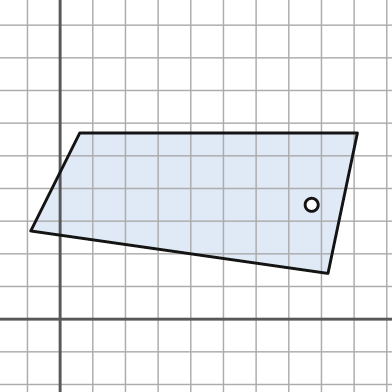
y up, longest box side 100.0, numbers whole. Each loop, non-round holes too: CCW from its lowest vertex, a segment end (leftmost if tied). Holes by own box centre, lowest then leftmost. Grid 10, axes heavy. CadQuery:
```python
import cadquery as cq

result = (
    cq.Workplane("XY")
    .moveTo(82.0, 14.0)
    .lineTo(91.0, 57.0)
    .lineTo(6.0, 57.0)
    .lineTo(-9.0, 27.0)
    .close()
    .moveTo(77.0, 35.0)
    .circle(2.0)
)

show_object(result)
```